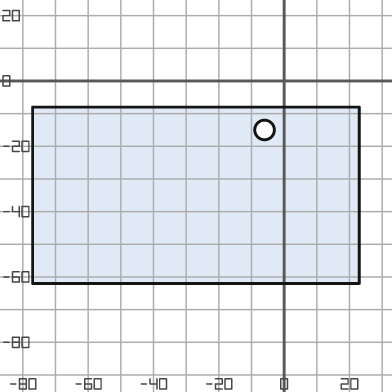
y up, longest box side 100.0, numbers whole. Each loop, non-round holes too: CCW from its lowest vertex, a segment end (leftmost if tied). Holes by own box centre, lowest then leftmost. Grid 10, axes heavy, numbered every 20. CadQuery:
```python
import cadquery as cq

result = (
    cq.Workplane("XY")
    .moveTo(-77.0, -62.0)
    .lineTo(23.0, -62.0)
    .lineTo(23.0, -8.0)
    .lineTo(-77.0, -8.0)
    .close()
    .moveTo(-6.0, -15.0)
    .circle(3.0)
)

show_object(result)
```